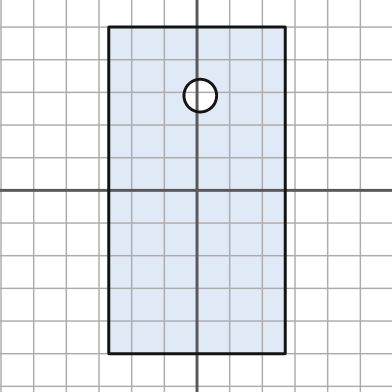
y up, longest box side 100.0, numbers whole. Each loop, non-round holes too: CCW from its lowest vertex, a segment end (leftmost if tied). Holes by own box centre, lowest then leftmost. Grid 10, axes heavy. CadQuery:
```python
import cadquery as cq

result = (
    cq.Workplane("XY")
    .moveTo(-27.0, -50.0)
    .lineTo(27.0, -50.0)
    .lineTo(27.0, 50.0)
    .lineTo(-27.0, 50.0)
    .close()
    .moveTo(1.0, 29.0)
    .circle(5.0)
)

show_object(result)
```